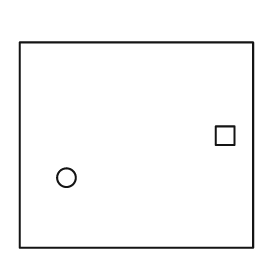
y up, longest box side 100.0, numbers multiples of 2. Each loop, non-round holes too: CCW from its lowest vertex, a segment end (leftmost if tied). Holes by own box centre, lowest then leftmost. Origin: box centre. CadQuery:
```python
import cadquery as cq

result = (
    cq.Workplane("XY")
    .moveTo(-50.0, -44.0)
    .lineTo(50.0, -44.0)
    .lineTo(50.0, 44.0)
    .lineTo(-50.0, 44.0)
    .close()
    .moveTo(-30.0, -14.0)
    .circle(4.0)
    .moveTo(34.0, 0.0)
    .lineTo(42.0, 0.0)
    .lineTo(42.0, 8.0)
    .lineTo(34.0, 8.0)
    .close()
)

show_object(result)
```